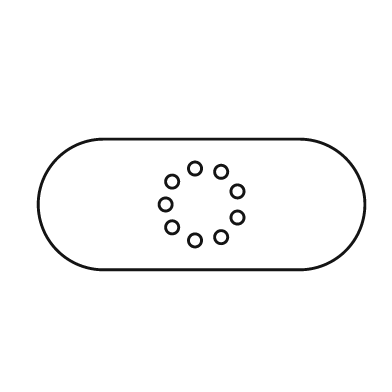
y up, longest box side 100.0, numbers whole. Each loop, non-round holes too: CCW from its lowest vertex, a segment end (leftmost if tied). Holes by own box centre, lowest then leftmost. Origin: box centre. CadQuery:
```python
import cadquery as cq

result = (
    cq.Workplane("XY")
    .moveTo(-30.0, -20.0)
    .lineTo(30.0, -20.0)
    .threePointArc((50.0, 0.0), (30.0, 20.0))
    .lineTo(-30.0, 20.0)
    .threePointArc((-50.0, 0.0), (-30.0, -20.0))
    .close()
    .moveTo(-2.0, -11.0)
    .circle(2.0)
    .moveTo(6.0, -10.0)
    .circle(2.0)
    .moveTo(-9.0, -7.0)
    .circle(2.0)
    .moveTo(11.0, -4.0)
    .circle(2.0)
    .moveTo(-11.0, 0.0)
    .circle(2.0)
    .moveTo(11.0, 4.0)
    .circle(2.0)
    .moveTo(-9.0, 7.0)
    .circle(2.0)
    .moveTo(6.0, 10.0)
    .circle(2.0)
    .moveTo(-2.0, 11.0)
    .circle(2.0)
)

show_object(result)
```